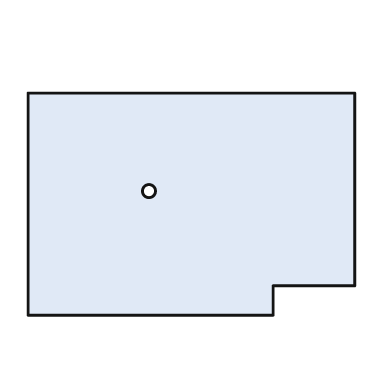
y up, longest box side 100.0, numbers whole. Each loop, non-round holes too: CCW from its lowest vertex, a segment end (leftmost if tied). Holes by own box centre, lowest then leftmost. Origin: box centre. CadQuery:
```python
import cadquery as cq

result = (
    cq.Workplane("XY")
    .moveTo(-50.0, -34.0)
    .lineTo(25.0, -34.0)
    .lineTo(25.0, -25.0)
    .lineTo(50.0, -25.0)
    .lineTo(50.0, 34.0)
    .lineTo(-50.0, 34.0)
    .close()
    .moveTo(-13.0, 4.0)
    .circle(2.0)
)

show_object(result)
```